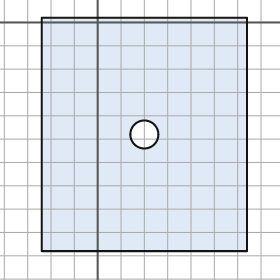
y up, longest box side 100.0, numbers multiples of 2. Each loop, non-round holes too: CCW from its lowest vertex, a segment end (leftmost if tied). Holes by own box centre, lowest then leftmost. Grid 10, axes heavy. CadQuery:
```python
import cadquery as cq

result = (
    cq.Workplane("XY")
    .moveTo(-24.0, -98.0)
    .lineTo(64.0, -98.0)
    .lineTo(64.0, 2.0)
    .lineTo(-24.0, 2.0)
    .close()
    .moveTo(20.0, -48.0)
    .circle(6.0)
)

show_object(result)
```